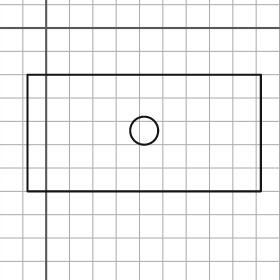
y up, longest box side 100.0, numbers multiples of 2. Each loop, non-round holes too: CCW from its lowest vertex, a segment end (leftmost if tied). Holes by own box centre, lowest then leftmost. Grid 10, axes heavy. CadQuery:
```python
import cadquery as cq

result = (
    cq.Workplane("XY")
    .moveTo(-8.0, -70.0)
    .lineTo(92.0, -70.0)
    .lineTo(92.0, -20.0)
    .lineTo(-8.0, -20.0)
    .close()
    .moveTo(42.0, -44.0)
    .circle(6.0)
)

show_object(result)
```